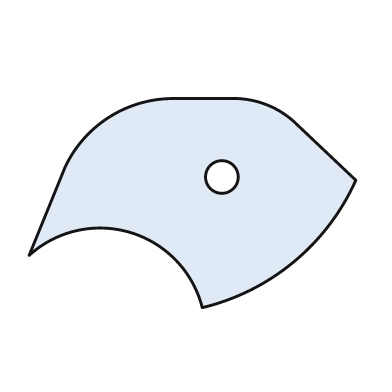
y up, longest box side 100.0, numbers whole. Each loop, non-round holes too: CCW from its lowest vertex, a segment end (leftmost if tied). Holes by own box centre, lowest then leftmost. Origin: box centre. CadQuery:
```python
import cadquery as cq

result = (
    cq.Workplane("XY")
    .moveTo(3.0, -32.0)
    .threePointArc((31.0, -18.0), (50.0, 7.0))
    .lineTo(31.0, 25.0)
    .threePointArc((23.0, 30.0), (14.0, 32.0))
    .lineTo(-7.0, 32.0)
    .threePointArc((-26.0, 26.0), (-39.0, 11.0))
    .lineTo(-50.0, -16.0)
    .threePointArc((-19.0, -9.0), (3.0, -32.0))
    .close()
    .moveTo(9.0, 8.0)
    .circle(5.0)
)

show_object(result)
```